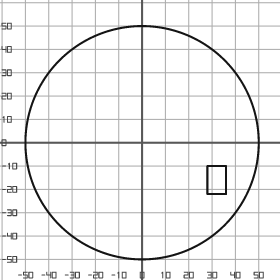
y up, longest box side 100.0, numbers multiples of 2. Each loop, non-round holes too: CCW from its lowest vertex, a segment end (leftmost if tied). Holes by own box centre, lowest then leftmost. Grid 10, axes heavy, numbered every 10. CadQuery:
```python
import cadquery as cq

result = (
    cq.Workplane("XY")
    .moveTo(0.0, 0.0)
    .circle(50.0)
    .moveTo(28.0, -22.0)
    .lineTo(36.0, -22.0)
    .lineTo(36.0, -10.0)
    .lineTo(28.0, -10.0)
    .close()
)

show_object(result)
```